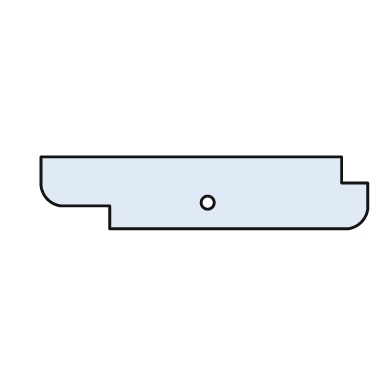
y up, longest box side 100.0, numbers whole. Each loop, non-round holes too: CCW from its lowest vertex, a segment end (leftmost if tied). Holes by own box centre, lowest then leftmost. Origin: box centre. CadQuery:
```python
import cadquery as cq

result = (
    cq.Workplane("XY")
    .moveTo(-29.0, -11.0)
    .lineTo(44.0, -11.0)
    .threePointArc((48.0, -9.0), (50.0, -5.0))
    .lineTo(50.0, 3.0)
    .lineTo(42.0, 3.0)
    .lineTo(42.0, 11.0)
    .lineTo(-50.0, 11.0)
    .lineTo(-50.0, 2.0)
    .threePointArc((-48.0, -2.0), (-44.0, -4.0))
    .lineTo(-29.0, -4.0)
    .close()
    .moveTo(1.0, -3.0)
    .circle(2.0)
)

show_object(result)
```